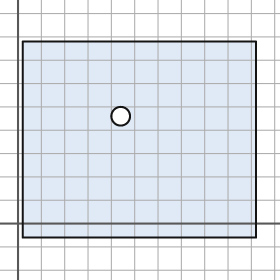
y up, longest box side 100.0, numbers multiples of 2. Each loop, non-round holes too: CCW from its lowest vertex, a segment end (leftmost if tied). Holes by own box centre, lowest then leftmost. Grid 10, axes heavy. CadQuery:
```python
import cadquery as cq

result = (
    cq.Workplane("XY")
    .moveTo(2.0, -6.0)
    .lineTo(102.0, -6.0)
    .lineTo(102.0, 78.0)
    .lineTo(2.0, 78.0)
    .close()
    .moveTo(44.0, 46.0)
    .circle(4.0)
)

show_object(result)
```